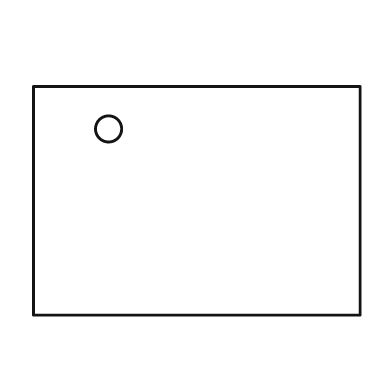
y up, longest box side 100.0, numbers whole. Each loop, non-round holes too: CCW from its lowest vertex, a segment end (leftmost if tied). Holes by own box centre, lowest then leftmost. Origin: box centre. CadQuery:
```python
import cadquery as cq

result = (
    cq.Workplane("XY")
    .moveTo(-50.0, -35.0)
    .lineTo(50.0, -35.0)
    .lineTo(50.0, 35.0)
    .lineTo(-50.0, 35.0)
    .close()
    .moveTo(-27.0, 22.0)
    .circle(4.0)
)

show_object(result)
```